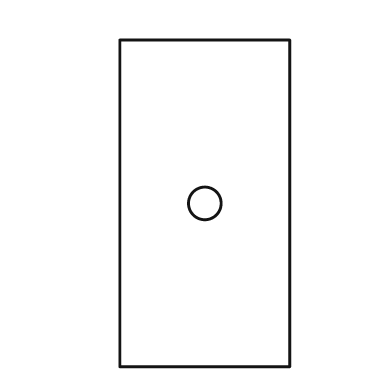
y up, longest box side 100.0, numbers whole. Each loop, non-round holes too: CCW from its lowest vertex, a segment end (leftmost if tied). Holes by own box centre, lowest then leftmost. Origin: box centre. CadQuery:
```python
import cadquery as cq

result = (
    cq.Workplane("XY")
    .moveTo(-26.0, -50.0)
    .lineTo(26.0, -50.0)
    .lineTo(26.0, 50.0)
    .lineTo(-26.0, 50.0)
    .close()
    .moveTo(0.0, 0.0)
    .circle(5.0)
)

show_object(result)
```